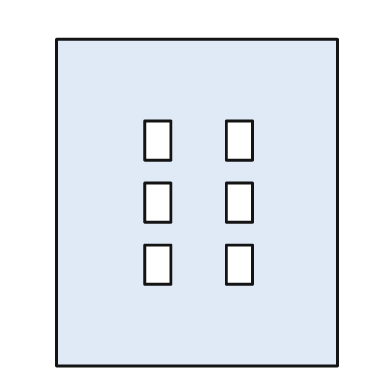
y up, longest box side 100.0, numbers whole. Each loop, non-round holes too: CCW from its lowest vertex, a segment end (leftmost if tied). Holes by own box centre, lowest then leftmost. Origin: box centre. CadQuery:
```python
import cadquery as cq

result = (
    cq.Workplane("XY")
    .moveTo(-43.0, -50.0)
    .lineTo(43.0, -50.0)
    .lineTo(43.0, 50.0)
    .lineTo(-43.0, 50.0)
    .close()
    .moveTo(-16.0, -25.0)
    .lineTo(-8.0, -25.0)
    .lineTo(-8.0, -13.0)
    .lineTo(-16.0, -13.0)
    .close()
    .moveTo(9.0, -25.0)
    .lineTo(17.0, -25.0)
    .lineTo(17.0, -13.0)
    .lineTo(9.0, -13.0)
    .close()
    .moveTo(-16.0, -6.0)
    .lineTo(-8.0, -6.0)
    .lineTo(-8.0, 6.0)
    .lineTo(-16.0, 6.0)
    .close()
    .moveTo(9.0, -6.0)
    .lineTo(17.0, -6.0)
    .lineTo(17.0, 6.0)
    .lineTo(9.0, 6.0)
    .close()
    .moveTo(-16.0, 13.0)
    .lineTo(-8.0, 13.0)
    .lineTo(-8.0, 25.0)
    .lineTo(-16.0, 25.0)
    .close()
    .moveTo(9.0, 13.0)
    .lineTo(17.0, 13.0)
    .lineTo(17.0, 25.0)
    .lineTo(9.0, 25.0)
    .close()
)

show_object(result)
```